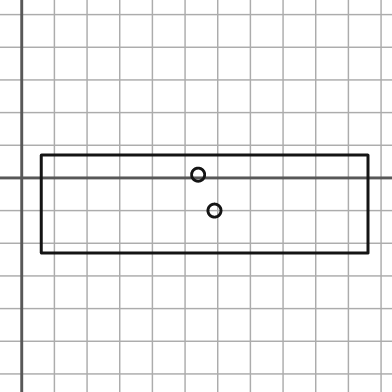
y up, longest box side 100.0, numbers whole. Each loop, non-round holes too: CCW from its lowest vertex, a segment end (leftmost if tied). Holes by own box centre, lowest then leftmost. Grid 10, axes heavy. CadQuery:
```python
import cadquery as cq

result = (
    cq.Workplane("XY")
    .moveTo(6.0, -23.0)
    .lineTo(106.0, -23.0)
    .lineTo(106.0, 7.0)
    .lineTo(6.0, 7.0)
    .close()
    .moveTo(59.0, -10.0)
    .circle(2.0)
    .moveTo(54.0, 1.0)
    .circle(2.0)
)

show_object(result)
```